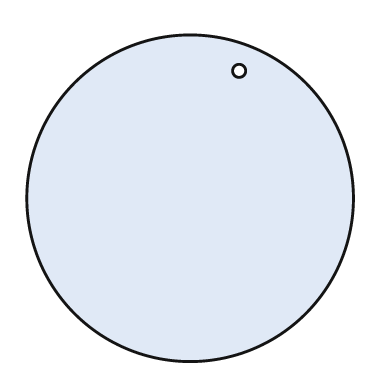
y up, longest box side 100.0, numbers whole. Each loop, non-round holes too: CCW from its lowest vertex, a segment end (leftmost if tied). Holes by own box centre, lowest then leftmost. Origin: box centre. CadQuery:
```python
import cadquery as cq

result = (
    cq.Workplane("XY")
    .moveTo(0.0, 0.0)
    .circle(50.0)
    .moveTo(15.0, 39.0)
    .circle(2.0)
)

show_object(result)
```